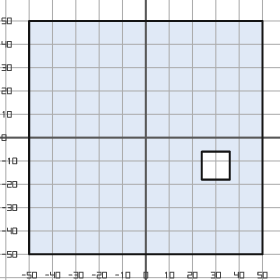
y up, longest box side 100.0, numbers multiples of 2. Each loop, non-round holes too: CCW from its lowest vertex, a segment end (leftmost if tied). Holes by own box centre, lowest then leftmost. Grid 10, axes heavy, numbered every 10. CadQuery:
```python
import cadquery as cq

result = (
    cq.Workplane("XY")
    .moveTo(-50.0, -50.0)
    .lineTo(50.0, -50.0)
    .lineTo(50.0, 50.0)
    .lineTo(-50.0, 50.0)
    .close()
    .moveTo(24.0, -18.0)
    .lineTo(36.0, -18.0)
    .lineTo(36.0, -6.0)
    .lineTo(24.0, -6.0)
    .close()
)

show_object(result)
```